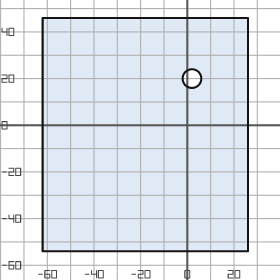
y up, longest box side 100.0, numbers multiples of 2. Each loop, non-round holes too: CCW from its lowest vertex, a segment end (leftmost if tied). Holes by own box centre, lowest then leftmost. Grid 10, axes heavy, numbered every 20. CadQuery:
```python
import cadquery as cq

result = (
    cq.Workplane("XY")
    .moveTo(-62.0, -54.0)
    .lineTo(26.0, -54.0)
    .lineTo(26.0, 46.0)
    .lineTo(-62.0, 46.0)
    .close()
    .moveTo(2.0, 20.0)
    .circle(4.0)
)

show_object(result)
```